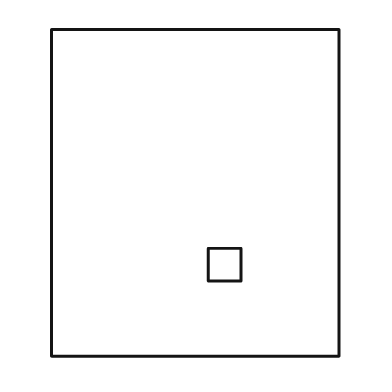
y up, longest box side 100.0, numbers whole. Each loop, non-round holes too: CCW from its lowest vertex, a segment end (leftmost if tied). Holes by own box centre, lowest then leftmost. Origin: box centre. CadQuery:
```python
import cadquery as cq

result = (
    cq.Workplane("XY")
    .moveTo(-44.0, -50.0)
    .lineTo(44.0, -50.0)
    .lineTo(44.0, 50.0)
    .lineTo(-44.0, 50.0)
    .close()
    .moveTo(4.0, -27.0)
    .lineTo(14.0, -27.0)
    .lineTo(14.0, -17.0)
    .lineTo(4.0, -17.0)
    .close()
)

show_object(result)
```